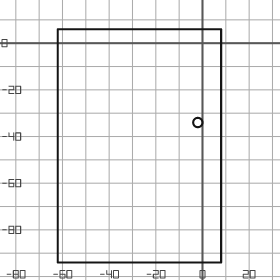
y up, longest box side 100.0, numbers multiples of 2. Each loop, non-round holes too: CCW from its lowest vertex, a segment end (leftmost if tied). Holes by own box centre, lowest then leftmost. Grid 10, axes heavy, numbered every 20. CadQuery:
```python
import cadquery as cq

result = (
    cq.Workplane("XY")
    .moveTo(-62.0, -94.0)
    .lineTo(8.0, -94.0)
    .lineTo(8.0, 6.0)
    .lineTo(-62.0, 6.0)
    .close()
    .moveTo(-2.0, -34.0)
    .circle(2.0)
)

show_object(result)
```